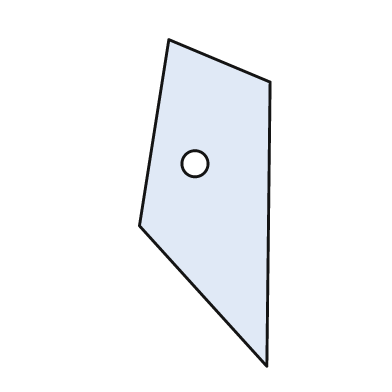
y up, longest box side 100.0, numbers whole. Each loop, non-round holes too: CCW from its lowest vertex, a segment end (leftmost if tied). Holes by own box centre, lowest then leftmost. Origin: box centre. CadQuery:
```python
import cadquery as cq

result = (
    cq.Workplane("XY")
    .moveTo(19.0, -50.0)
    .lineTo(20.0, 37.0)
    .lineTo(-11.0, 50.0)
    .lineTo(-20.0, -7.0)
    .close()
    .moveTo(-3.0, 12.0)
    .circle(4.0)
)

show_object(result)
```